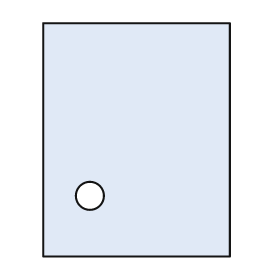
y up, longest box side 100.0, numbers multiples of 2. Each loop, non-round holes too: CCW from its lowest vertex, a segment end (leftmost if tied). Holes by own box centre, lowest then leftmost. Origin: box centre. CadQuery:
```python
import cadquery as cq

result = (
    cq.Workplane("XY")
    .moveTo(-40.0, -50.0)
    .lineTo(40.0, -50.0)
    .lineTo(40.0, 50.0)
    .lineTo(-40.0, 50.0)
    .close()
    .moveTo(-20.0, -24.0)
    .circle(6.0)
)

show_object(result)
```